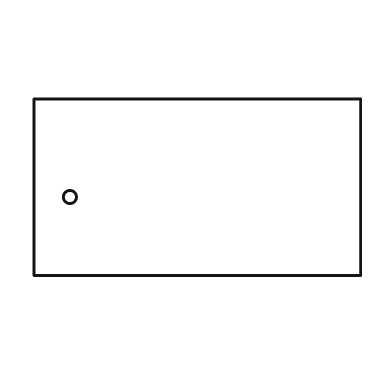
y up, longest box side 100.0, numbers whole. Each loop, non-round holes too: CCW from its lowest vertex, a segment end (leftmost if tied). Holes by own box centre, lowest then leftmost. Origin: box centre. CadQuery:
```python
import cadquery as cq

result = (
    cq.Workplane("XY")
    .moveTo(-50.0, -27.0)
    .lineTo(50.0, -27.0)
    .lineTo(50.0, 27.0)
    .lineTo(-50.0, 27.0)
    .close()
    .moveTo(-39.0, -3.0)
    .circle(2.0)
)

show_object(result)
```